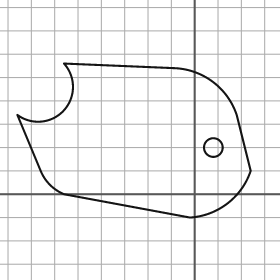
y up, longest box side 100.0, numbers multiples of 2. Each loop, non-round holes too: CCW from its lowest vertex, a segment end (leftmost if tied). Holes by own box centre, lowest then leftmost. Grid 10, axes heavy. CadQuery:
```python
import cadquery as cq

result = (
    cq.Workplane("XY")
    .moveTo(-2.0, -10.0)
    .threePointArc((14.0, -4.0), (24.0, 10.0))
    .lineTo(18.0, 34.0)
    .threePointArc((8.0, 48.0), (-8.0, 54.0))
    .lineTo(-56.0, 56.0)
    .threePointArc((-56.0, 36.0), (-76.0, 34.0))
    .lineTo(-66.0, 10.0)
    .threePointArc((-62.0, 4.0), (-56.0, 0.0))
    .close()
    .moveTo(8.0, 20.0)
    .circle(4.0)
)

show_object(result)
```